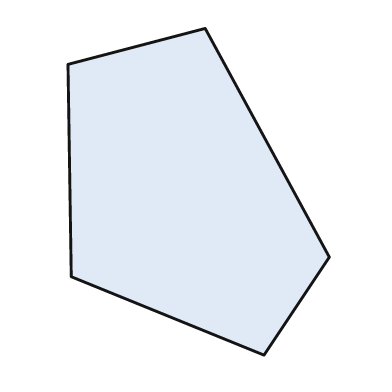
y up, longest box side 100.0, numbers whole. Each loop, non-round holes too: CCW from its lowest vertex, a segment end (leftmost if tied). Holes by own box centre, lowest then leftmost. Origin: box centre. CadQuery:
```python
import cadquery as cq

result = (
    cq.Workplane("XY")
    .moveTo(20.0, -50.0)
    .lineTo(40.0, -20.0)
    .lineTo(2.0, 50.0)
    .lineTo(-40.0, 39.0)
    .lineTo(-39.0, -26.0)
    .close()
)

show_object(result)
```